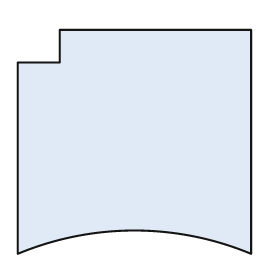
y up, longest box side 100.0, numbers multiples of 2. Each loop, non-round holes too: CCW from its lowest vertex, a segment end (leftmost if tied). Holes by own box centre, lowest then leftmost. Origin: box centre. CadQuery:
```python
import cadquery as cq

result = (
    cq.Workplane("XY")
    .moveTo(-50.0, -48.0)
    .threePointArc((0.0, -38.0), (50.0, -48.0))
    .lineTo(50.0, 48.0)
    .lineTo(-32.0, 48.0)
    .lineTo(-32.0, 34.0)
    .lineTo(-50.0, 34.0)
    .close()
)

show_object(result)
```